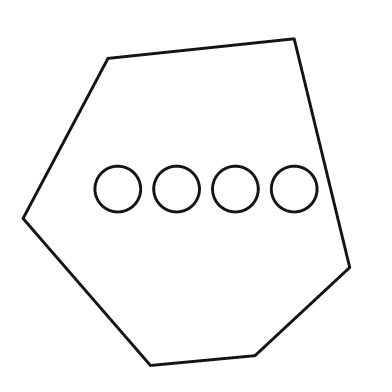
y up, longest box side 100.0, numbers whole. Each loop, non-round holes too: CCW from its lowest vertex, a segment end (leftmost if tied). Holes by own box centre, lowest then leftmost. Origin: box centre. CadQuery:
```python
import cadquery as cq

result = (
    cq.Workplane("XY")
    .moveTo(-11.0, -50.0)
    .lineTo(21.0, -47.0)
    .lineTo(50.0, -20.0)
    .lineTo(33.0, 50.0)
    .lineTo(-24.0, 44.0)
    .lineTo(-50.0, -5.0)
    .close()
    .moveTo(-21.0, 4.0)
    .circle(7.0)
    .moveTo(-3.0, 4.0)
    .circle(7.0)
    .moveTo(15.0, 4.0)
    .circle(7.0)
    .moveTo(33.0, 4.0)
    .circle(7.0)
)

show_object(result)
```